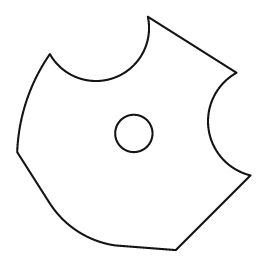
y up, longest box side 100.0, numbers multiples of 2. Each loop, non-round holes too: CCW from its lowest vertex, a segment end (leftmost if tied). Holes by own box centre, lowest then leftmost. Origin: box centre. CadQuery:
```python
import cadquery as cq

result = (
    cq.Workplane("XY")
    .moveTo(18.0, -50.0)
    .lineTo(50.0, -18.0)
    .threePointArc((32.0, 2.0), (44.0, 26.0))
    .lineTo(6.0, 50.0)
    .threePointArc((-8.0, 24.0), (-36.0, 34.0))
    .threePointArc((-46.0, 14.0), (-50.0, -8.0))
    .lineTo(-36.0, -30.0)
    .threePointArc((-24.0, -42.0), (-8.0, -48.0))
    .close()
    .moveTo(0.0, 0.0)
    .circle(8.0)
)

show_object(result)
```